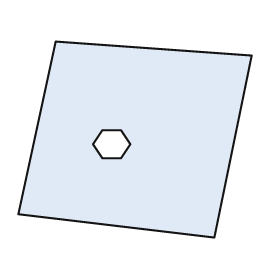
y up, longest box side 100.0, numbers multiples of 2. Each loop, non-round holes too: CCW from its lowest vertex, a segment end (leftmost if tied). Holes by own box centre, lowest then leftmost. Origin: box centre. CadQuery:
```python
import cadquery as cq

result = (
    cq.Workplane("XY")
    .moveTo(34.0, -42.0)
    .lineTo(50.0, 36.0)
    .lineTo(-34.0, 42.0)
    .lineTo(-50.0, -32.0)
    .close()
    .moveTo(-14.0, -8.0)
    .lineTo(-6.0, -8.0)
    .lineTo(-2.0, -2.0)
    .lineTo(-6.0, 4.0)
    .lineTo(-14.0, 4.0)
    .lineTo(-18.0, -2.0)
    .close()
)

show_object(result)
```